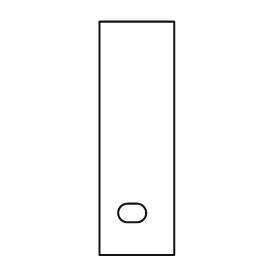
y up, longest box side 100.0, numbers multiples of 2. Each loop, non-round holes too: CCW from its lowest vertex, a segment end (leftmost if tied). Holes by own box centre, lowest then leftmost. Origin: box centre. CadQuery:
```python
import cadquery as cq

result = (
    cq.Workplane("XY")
    .moveTo(-16.0, -50.0)
    .lineTo(16.0, -50.0)
    .lineTo(16.0, 50.0)
    .lineTo(-16.0, 50.0)
    .close()
    .moveTo(-4.0, -36.0)
    .lineTo(0.0, -36.0)
    .threePointArc((4.0, -32.0), (0.0, -28.0))
    .lineTo(-4.0, -28.0)
    .threePointArc((-8.0, -32.0), (-4.0, -36.0))
    .close()
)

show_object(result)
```